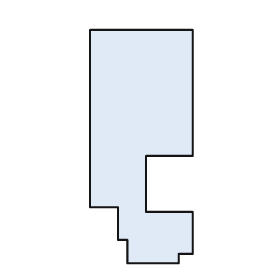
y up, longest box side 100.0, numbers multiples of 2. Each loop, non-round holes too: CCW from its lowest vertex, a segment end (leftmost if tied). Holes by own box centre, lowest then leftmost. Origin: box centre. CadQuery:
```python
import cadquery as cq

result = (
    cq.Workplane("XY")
    .moveTo(-6.0, -50.0)
    .lineTo(16.0, -50.0)
    .lineTo(16.0, -46.0)
    .lineTo(22.0, -46.0)
    .lineTo(22.0, -28.0)
    .lineTo(2.0, -28.0)
    .lineTo(2.0, -4.0)
    .lineTo(22.0, -4.0)
    .lineTo(22.0, 50.0)
    .lineTo(-22.0, 50.0)
    .lineTo(-22.0, -26.0)
    .lineTo(-10.0, -26.0)
    .lineTo(-10.0, -40.0)
    .lineTo(-6.0, -40.0)
    .close()
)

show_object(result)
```